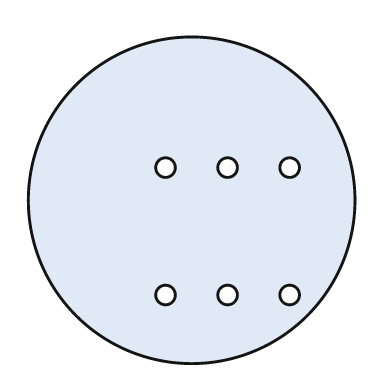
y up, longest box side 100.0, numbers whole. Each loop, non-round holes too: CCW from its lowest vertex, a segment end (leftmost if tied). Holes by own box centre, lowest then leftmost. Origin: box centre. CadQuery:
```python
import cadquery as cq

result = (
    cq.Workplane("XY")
    .moveTo(0.0, 0.0)
    .circle(50.0)
    .moveTo(-8.0, -29.0)
    .circle(3.0)
    .moveTo(11.0, -29.0)
    .circle(3.0)
    .moveTo(30.0, -29.0)
    .circle(3.0)
    .moveTo(-8.0, 10.0)
    .circle(3.0)
    .moveTo(11.0, 10.0)
    .circle(3.0)
    .moveTo(30.0, 10.0)
    .circle(3.0)
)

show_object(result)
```